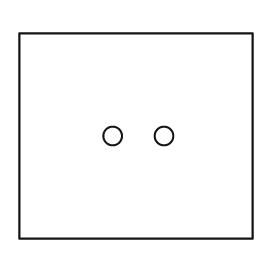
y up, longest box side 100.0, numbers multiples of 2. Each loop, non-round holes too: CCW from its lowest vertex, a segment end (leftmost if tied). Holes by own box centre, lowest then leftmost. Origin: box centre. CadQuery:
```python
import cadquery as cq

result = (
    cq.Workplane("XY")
    .moveTo(-50.0, -44.0)
    .lineTo(50.0, -44.0)
    .lineTo(50.0, 44.0)
    .lineTo(-50.0, 44.0)
    .close()
    .moveTo(-10.0, 0.0)
    .circle(4.0)
    .moveTo(12.0, 0.0)
    .circle(4.0)
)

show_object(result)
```